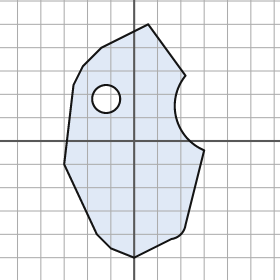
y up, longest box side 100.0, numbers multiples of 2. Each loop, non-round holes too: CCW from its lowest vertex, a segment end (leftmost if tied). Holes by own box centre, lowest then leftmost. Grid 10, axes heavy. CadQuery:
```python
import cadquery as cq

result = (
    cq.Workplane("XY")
    .moveTo(0.0, -50.0)
    .lineTo(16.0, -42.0)
    .threePointArc((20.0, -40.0), (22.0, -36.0))
    .lineTo(30.0, -4.0)
    .threePointArc((18.0, 10.0), (22.0, 28.0))
    .lineTo(6.0, 50.0)
    .lineTo(-14.0, 40.0)
    .lineTo(-22.0, 32.0)
    .lineTo(-26.0, 24.0)
    .lineTo(-30.0, -10.0)
    .lineTo(-16.0, -40.0)
    .lineTo(-10.0, -46.0)
    .close()
    .moveTo(-12.0, 18.0)
    .circle(6.0)
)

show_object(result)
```